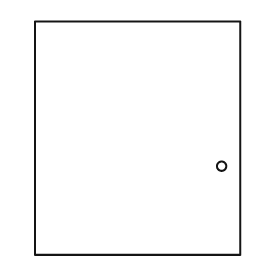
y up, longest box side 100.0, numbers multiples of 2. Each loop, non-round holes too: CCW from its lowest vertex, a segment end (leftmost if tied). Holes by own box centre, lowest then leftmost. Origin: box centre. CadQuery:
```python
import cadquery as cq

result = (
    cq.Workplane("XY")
    .moveTo(-44.0, -50.0)
    .lineTo(44.0, -50.0)
    .lineTo(44.0, 50.0)
    .lineTo(-44.0, 50.0)
    .close()
    .moveTo(36.0, -12.0)
    .circle(2.0)
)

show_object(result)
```